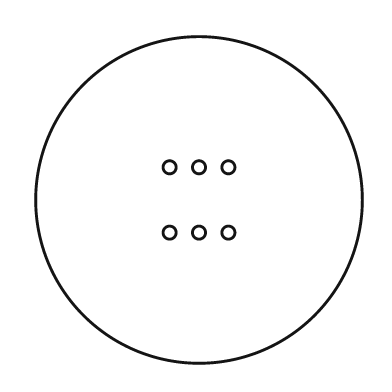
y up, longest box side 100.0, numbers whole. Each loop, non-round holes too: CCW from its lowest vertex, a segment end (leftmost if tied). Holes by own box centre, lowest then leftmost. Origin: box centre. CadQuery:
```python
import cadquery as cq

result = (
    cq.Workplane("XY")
    .moveTo(0.0, 0.0)
    .circle(50.0)
    .moveTo(-9.0, -10.0)
    .circle(2.0)
    .moveTo(0.0, -10.0)
    .circle(2.0)
    .moveTo(9.0, -10.0)
    .circle(2.0)
    .moveTo(-9.0, 10.0)
    .circle(2.0)
    .moveTo(0.0, 10.0)
    .circle(2.0)
    .moveTo(9.0, 10.0)
    .circle(2.0)
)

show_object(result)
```